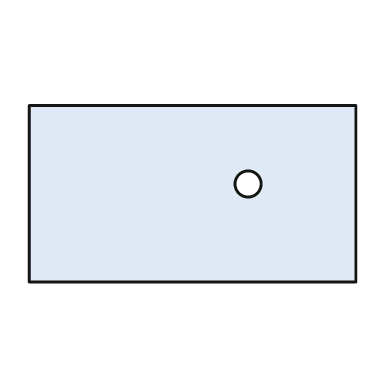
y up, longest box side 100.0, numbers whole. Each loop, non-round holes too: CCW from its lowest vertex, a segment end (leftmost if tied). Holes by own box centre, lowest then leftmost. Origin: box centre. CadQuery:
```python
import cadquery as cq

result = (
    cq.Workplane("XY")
    .moveTo(-50.0, -27.0)
    .lineTo(50.0, -27.0)
    .lineTo(50.0, 27.0)
    .lineTo(-50.0, 27.0)
    .close()
    .moveTo(17.0, 3.0)
    .circle(4.0)
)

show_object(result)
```